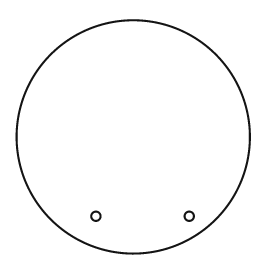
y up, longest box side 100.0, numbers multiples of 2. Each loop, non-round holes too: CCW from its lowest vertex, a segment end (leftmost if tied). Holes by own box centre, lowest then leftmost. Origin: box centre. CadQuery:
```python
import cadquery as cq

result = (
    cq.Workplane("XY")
    .moveTo(0.0, 0.0)
    .circle(50.0)
    .moveTo(-16.0, -34.0)
    .circle(2.0)
    .moveTo(24.0, -34.0)
    .circle(2.0)
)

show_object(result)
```